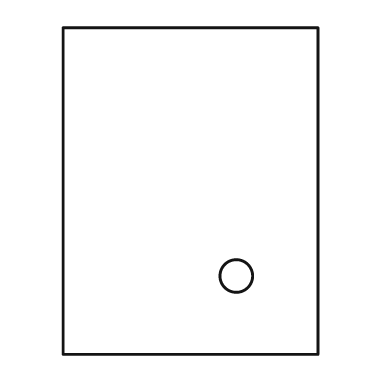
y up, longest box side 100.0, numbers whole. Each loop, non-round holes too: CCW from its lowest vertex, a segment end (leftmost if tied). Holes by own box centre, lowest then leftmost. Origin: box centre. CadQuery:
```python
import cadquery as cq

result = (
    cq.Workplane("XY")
    .moveTo(-39.0, -50.0)
    .lineTo(39.0, -50.0)
    .lineTo(39.0, 50.0)
    .lineTo(-39.0, 50.0)
    .close()
    .moveTo(14.0, -26.0)
    .circle(5.0)
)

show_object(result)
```